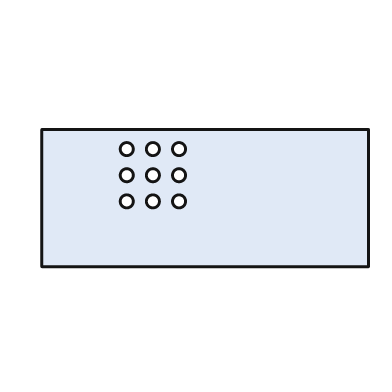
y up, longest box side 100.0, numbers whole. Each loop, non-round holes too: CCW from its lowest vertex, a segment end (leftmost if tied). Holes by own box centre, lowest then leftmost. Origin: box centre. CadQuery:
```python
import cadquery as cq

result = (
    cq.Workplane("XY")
    .moveTo(-50.0, -21.0)
    .lineTo(50.0, -21.0)
    .lineTo(50.0, 21.0)
    .lineTo(-50.0, 21.0)
    .close()
    .moveTo(-24.0, -1.0)
    .circle(2.0)
    .moveTo(-16.0, -1.0)
    .circle(2.0)
    .moveTo(-8.0, -1.0)
    .circle(2.0)
    .moveTo(-24.0, 7.0)
    .circle(2.0)
    .moveTo(-16.0, 7.0)
    .circle(2.0)
    .moveTo(-8.0, 7.0)
    .circle(2.0)
    .moveTo(-24.0, 15.0)
    .circle(2.0)
    .moveTo(-16.0, 15.0)
    .circle(2.0)
    .moveTo(-8.0, 15.0)
    .circle(2.0)
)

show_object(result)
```